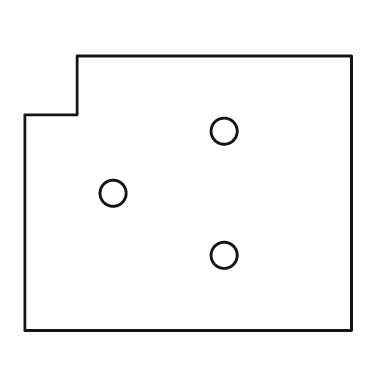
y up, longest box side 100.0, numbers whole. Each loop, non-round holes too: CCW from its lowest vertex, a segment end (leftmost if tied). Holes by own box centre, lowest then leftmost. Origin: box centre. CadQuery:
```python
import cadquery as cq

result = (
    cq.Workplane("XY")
    .moveTo(-50.0, -42.0)
    .lineTo(50.0, -42.0)
    .lineTo(50.0, 42.0)
    .lineTo(-34.0, 42.0)
    .lineTo(-34.0, 24.0)
    .lineTo(-50.0, 24.0)
    .close()
    .moveTo(11.0, -19.0)
    .circle(4.0)
    .moveTo(-23.0, 0.0)
    .circle(4.0)
    .moveTo(11.0, 19.0)
    .circle(4.0)
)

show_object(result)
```